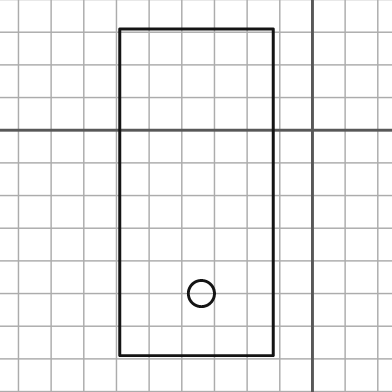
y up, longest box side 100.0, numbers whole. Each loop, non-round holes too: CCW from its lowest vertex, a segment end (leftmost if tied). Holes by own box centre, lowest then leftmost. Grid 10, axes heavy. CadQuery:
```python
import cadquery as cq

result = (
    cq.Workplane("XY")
    .moveTo(-59.0, -69.0)
    .lineTo(-12.0, -69.0)
    .lineTo(-12.0, 31.0)
    .lineTo(-59.0, 31.0)
    .close()
    .moveTo(-34.0, -50.0)
    .circle(4.0)
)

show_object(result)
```